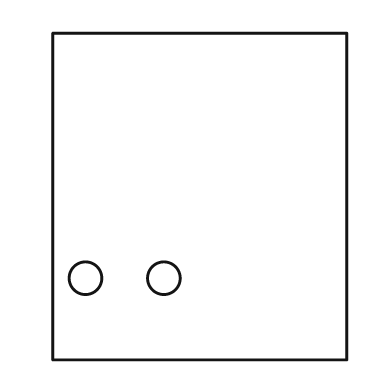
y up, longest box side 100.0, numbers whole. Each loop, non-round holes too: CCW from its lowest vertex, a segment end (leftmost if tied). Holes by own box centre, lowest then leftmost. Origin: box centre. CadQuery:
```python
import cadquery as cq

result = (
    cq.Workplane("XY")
    .moveTo(-45.0, -50.0)
    .lineTo(45.0, -50.0)
    .lineTo(45.0, 50.0)
    .lineTo(-45.0, 50.0)
    .close()
    .moveTo(-35.0, -25.0)
    .circle(5.0)
    .moveTo(-11.0, -25.0)
    .circle(5.0)
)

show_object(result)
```